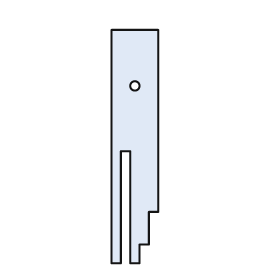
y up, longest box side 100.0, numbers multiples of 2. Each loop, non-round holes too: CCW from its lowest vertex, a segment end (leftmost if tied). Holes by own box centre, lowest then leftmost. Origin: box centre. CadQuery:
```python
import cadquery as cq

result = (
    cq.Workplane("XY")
    .moveTo(-10.0, -50.0)
    .lineTo(-6.0, -50.0)
    .lineTo(-6.0, -2.0)
    .lineTo(-2.0, -2.0)
    .lineTo(-2.0, -50.0)
    .lineTo(2.0, -50.0)
    .lineTo(2.0, -42.0)
    .lineTo(6.0, -42.0)
    .lineTo(6.0, -28.0)
    .lineTo(10.0, -28.0)
    .lineTo(10.0, 50.0)
    .lineTo(-10.0, 50.0)
    .close()
    .moveTo(0.0, 26.0)
    .circle(2.0)
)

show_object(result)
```